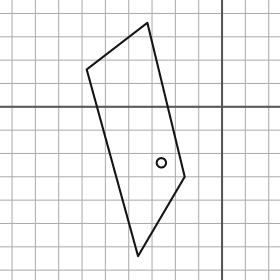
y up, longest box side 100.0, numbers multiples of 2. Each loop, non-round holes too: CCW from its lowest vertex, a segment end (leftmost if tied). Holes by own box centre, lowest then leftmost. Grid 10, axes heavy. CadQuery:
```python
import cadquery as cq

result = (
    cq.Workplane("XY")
    .moveTo(-36.0, -64.0)
    .lineTo(-16.0, -30.0)
    .lineTo(-32.0, 36.0)
    .lineTo(-58.0, 16.0)
    .close()
    .moveTo(-26.0, -24.0)
    .circle(2.0)
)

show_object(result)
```